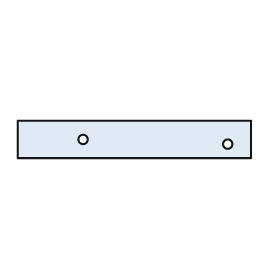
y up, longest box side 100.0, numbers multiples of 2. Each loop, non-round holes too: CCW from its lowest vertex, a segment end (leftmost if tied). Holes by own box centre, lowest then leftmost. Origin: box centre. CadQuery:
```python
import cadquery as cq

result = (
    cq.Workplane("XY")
    .moveTo(-50.0, -8.0)
    .lineTo(50.0, -8.0)
    .lineTo(50.0, 8.0)
    .lineTo(-50.0, 8.0)
    .close()
    .moveTo(40.0, -2.0)
    .circle(2.0)
    .moveTo(-22.0, 0.0)
    .circle(2.0)
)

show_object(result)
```